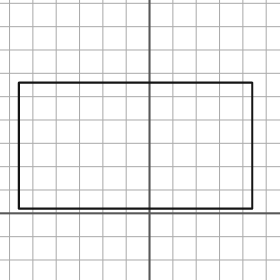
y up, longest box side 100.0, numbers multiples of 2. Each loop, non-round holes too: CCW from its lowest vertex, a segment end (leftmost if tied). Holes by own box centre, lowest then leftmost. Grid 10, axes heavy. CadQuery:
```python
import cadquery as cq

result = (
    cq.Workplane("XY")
    .moveTo(-56.0, 2.0)
    .lineTo(44.0, 2.0)
    .lineTo(44.0, 56.0)
    .lineTo(-56.0, 56.0)
    .close()
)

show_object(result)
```